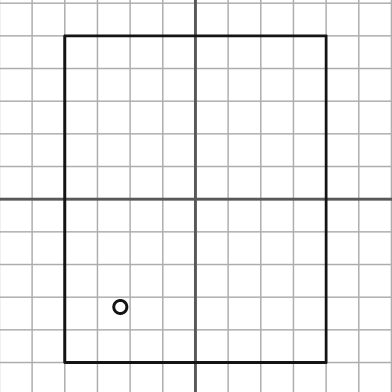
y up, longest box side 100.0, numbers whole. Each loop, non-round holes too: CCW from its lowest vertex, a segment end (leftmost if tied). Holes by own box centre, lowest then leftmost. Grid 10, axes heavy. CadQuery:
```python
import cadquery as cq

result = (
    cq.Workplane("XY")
    .moveTo(-40.0, -50.0)
    .lineTo(40.0, -50.0)
    .lineTo(40.0, 50.0)
    .lineTo(-40.0, 50.0)
    .close()
    .moveTo(-23.0, -33.0)
    .circle(2.0)
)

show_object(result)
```